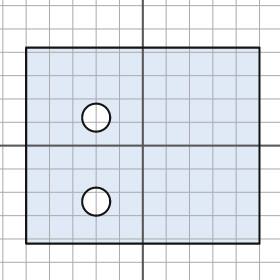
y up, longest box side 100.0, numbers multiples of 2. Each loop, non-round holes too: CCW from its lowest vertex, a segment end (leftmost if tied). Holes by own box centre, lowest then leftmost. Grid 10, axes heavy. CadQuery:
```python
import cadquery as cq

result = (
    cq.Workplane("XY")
    .moveTo(-50.0, -42.0)
    .lineTo(50.0, -42.0)
    .lineTo(50.0, 42.0)
    .lineTo(-50.0, 42.0)
    .close()
    .moveTo(-20.0, -24.0)
    .circle(6.0)
    .moveTo(-20.0, 12.0)
    .circle(6.0)
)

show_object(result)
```